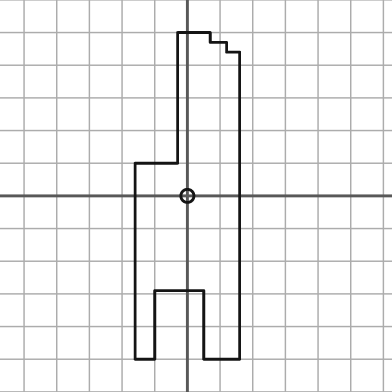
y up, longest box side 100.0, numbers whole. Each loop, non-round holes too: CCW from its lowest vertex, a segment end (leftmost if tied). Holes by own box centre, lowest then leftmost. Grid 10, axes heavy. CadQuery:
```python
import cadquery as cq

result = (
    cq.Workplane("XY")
    .moveTo(-16.0, -50.0)
    .lineTo(-10.0, -50.0)
    .lineTo(-10.0, -29.0)
    .lineTo(5.0, -29.0)
    .lineTo(5.0, -50.0)
    .lineTo(16.0, -50.0)
    .lineTo(16.0, 44.0)
    .lineTo(12.0, 44.0)
    .lineTo(12.0, 47.0)
    .lineTo(7.0, 47.0)
    .lineTo(7.0, 50.0)
    .lineTo(-3.0, 50.0)
    .lineTo(-3.0, 10.0)
    .lineTo(-16.0, 10.0)
    .close()
    .moveTo(0.0, 0.0)
    .circle(2.0)
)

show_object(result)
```